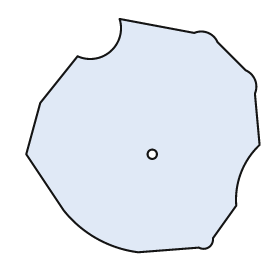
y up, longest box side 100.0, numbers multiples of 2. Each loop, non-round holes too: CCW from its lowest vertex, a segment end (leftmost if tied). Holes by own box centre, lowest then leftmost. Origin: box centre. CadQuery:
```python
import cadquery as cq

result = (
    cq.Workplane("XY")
    .moveTo(-2.0, -50.0)
    .lineTo(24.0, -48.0)
    .threePointArc((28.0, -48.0), (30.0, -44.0))
    .lineTo(40.0, -30.0)
    .threePointArc((42.0, -16.0), (50.0, -4.0))
    .lineTo(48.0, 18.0)
    .threePointArc((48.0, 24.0), (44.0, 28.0))
    .lineTo(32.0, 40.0)
    .threePointArc((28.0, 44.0), (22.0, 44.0))
    .lineTo(-10.0, 50.0)
    .threePointArc((-14.0, 36.0), (-28.0, 34.0))
    .lineTo(-44.0, 14.0)
    .lineTo(-50.0, -8.0)
    .lineTo(-34.0, -32.0)
    .threePointArc((-20.0, -44.0), (-2.0, -50.0))
    .close()
    .moveTo(4.0, -8.0)
    .circle(2.0)
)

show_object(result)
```